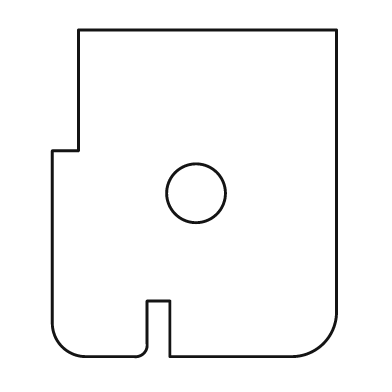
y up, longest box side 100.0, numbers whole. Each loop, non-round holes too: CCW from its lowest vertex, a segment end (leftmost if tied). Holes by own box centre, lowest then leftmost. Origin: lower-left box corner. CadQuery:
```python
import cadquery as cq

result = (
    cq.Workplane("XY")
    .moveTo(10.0, 0.0)
    .lineTo(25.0, 0.0)
    .threePointArc((28.0, 1.0), (29.0, 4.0))
    .lineTo(29.0, 17.0)
    .lineTo(36.0, 17.0)
    .lineTo(36.0, 0.0)
    .lineTo(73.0, 0.0)
    .threePointArc((83.0, 4.0), (87.0, 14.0))
    .lineTo(87.0, 100.0)
    .lineTo(8.0, 100.0)
    .lineTo(8.0, 63.0)
    .lineTo(0.0, 63.0)
    .lineTo(0.0, 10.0)
    .threePointArc((3.0, 3.0), (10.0, 0.0))
    .close()
    .moveTo(44.0, 50.0)
    .circle(9.0)
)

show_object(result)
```